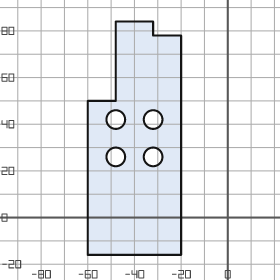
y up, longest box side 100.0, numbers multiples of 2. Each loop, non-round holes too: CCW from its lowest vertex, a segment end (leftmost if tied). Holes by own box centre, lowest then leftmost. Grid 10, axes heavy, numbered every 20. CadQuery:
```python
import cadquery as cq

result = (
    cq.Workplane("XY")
    .moveTo(-60.0, -16.0)
    .lineTo(-20.0, -16.0)
    .lineTo(-20.0, 78.0)
    .lineTo(-32.0, 78.0)
    .lineTo(-32.0, 84.0)
    .lineTo(-48.0, 84.0)
    .lineTo(-48.0, 50.0)
    .lineTo(-60.0, 50.0)
    .close()
    .moveTo(-48.0, 26.0)
    .circle(4.0)
    .moveTo(-32.0, 26.0)
    .circle(4.0)
    .moveTo(-48.0, 42.0)
    .circle(4.0)
    .moveTo(-32.0, 42.0)
    .circle(4.0)
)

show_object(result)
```